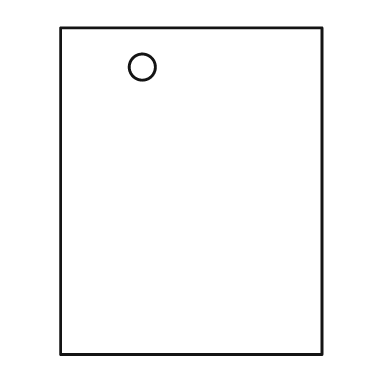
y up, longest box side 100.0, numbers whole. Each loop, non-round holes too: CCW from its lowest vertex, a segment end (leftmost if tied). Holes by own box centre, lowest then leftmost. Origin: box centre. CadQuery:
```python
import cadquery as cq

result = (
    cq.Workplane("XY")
    .moveTo(-40.0, -50.0)
    .lineTo(40.0, -50.0)
    .lineTo(40.0, 50.0)
    .lineTo(-40.0, 50.0)
    .close()
    .moveTo(-15.0, 38.0)
    .circle(4.0)
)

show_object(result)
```